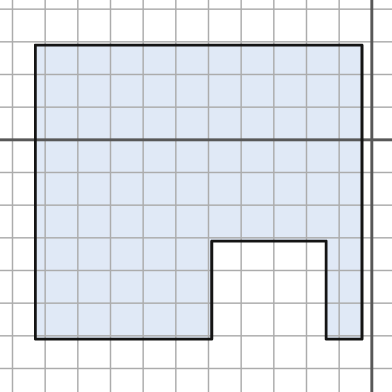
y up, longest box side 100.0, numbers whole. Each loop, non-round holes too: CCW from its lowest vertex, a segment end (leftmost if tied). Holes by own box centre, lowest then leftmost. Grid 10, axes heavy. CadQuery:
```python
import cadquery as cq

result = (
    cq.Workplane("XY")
    .moveTo(-103.0, -61.0)
    .lineTo(-49.0, -61.0)
    .lineTo(-49.0, -31.0)
    .lineTo(-14.0, -31.0)
    .lineTo(-14.0, -61.0)
    .lineTo(-3.0, -61.0)
    .lineTo(-3.0, 29.0)
    .lineTo(-103.0, 29.0)
    .close()
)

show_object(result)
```